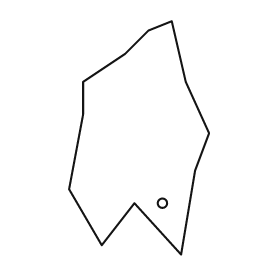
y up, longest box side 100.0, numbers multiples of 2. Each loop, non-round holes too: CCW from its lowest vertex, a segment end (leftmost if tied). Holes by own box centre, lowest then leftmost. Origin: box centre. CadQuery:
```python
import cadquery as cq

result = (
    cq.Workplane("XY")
    .moveTo(18.0, -50.0)
    .lineTo(24.0, -14.0)
    .lineTo(30.0, 2.0)
    .lineTo(20.0, 24.0)
    .lineTo(14.0, 50.0)
    .lineTo(4.0, 46.0)
    .lineTo(-6.0, 36.0)
    .lineTo(-24.0, 24.0)
    .lineTo(-24.0, 10.0)
    .lineTo(-30.0, -22.0)
    .lineTo(-16.0, -46.0)
    .lineTo(-2.0, -28.0)
    .close()
    .moveTo(10.0, -28.0)
    .circle(2.0)
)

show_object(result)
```